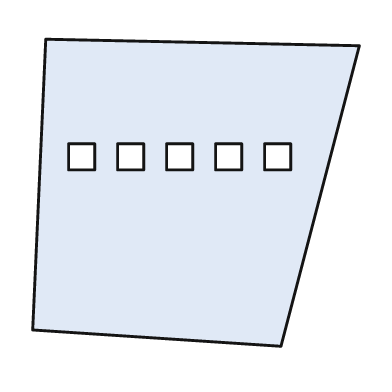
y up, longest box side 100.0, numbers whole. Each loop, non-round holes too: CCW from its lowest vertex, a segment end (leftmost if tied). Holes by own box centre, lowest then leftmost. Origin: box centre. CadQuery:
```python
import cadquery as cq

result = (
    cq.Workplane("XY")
    .moveTo(26.0, -47.0)
    .lineTo(50.0, 45.0)
    .lineTo(-46.0, 47.0)
    .lineTo(-50.0, -42.0)
    .close()
    .moveTo(-39.0, 7.0)
    .lineTo(-31.0, 7.0)
    .lineTo(-31.0, 15.0)
    .lineTo(-39.0, 15.0)
    .close()
    .moveTo(-24.0, 7.0)
    .lineTo(-16.0, 7.0)
    .lineTo(-16.0, 15.0)
    .lineTo(-24.0, 15.0)
    .close()
    .moveTo(-9.0, 7.0)
    .lineTo(-1.0, 7.0)
    .lineTo(-1.0, 15.0)
    .lineTo(-9.0, 15.0)
    .close()
    .moveTo(6.0, 7.0)
    .lineTo(14.0, 7.0)
    .lineTo(14.0, 15.0)
    .lineTo(6.0, 15.0)
    .close()
    .moveTo(21.0, 7.0)
    .lineTo(29.0, 7.0)
    .lineTo(29.0, 15.0)
    .lineTo(21.0, 15.0)
    .close()
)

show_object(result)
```